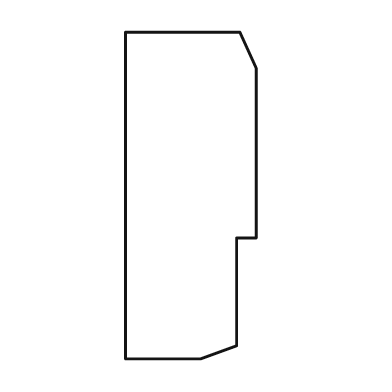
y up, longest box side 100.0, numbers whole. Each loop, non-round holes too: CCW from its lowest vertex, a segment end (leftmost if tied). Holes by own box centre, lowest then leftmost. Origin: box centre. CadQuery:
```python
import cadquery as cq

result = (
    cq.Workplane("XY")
    .moveTo(-20.0, -50.0)
    .lineTo(3.0, -50.0)
    .lineTo(14.0, -46.0)
    .lineTo(14.0, -13.0)
    .lineTo(20.0, -13.0)
    .lineTo(20.0, 39.0)
    .lineTo(15.0, 50.0)
    .lineTo(-20.0, 50.0)
    .close()
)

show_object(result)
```